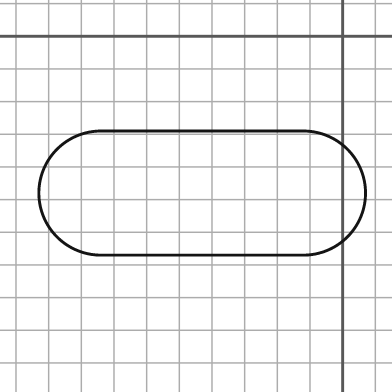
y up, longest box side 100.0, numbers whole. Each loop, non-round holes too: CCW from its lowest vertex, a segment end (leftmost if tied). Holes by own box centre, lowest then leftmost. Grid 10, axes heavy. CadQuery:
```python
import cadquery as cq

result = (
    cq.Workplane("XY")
    .moveTo(-74.0, -67.0)
    .lineTo(-12.0, -67.0)
    .threePointArc((7.0, -48.0), (-12.0, -29.0))
    .lineTo(-74.0, -29.0)
    .threePointArc((-93.0, -48.0), (-74.0, -67.0))
    .close()
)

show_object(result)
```